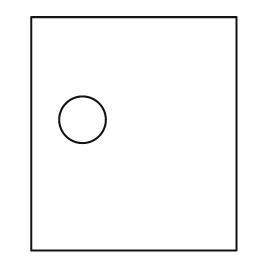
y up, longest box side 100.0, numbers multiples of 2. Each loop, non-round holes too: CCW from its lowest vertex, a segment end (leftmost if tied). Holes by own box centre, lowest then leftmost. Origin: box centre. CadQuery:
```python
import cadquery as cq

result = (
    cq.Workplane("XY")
    .moveTo(-44.0, -50.0)
    .lineTo(44.0, -50.0)
    .lineTo(44.0, 50.0)
    .lineTo(-44.0, 50.0)
    .close()
    .moveTo(-22.0, 6.0)
    .circle(10.0)
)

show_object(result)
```